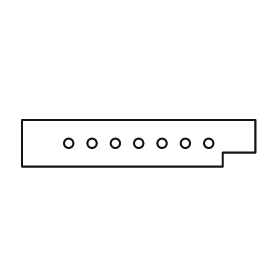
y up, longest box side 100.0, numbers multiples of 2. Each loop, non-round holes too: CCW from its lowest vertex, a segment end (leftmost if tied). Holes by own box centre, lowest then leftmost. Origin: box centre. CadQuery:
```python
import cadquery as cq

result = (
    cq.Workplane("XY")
    .moveTo(-50.0, -10.0)
    .lineTo(36.0, -10.0)
    .lineTo(36.0, -4.0)
    .lineTo(50.0, -4.0)
    .lineTo(50.0, 10.0)
    .lineTo(-50.0, 10.0)
    .close()
    .moveTo(-30.0, 0.0)
    .circle(2.0)
    .moveTo(-20.0, 0.0)
    .circle(2.0)
    .moveTo(-10.0, 0.0)
    .circle(2.0)
    .moveTo(0.0, 0.0)
    .circle(2.0)
    .moveTo(10.0, 0.0)
    .circle(2.0)
    .moveTo(20.0, 0.0)
    .circle(2.0)
    .moveTo(30.0, 0.0)
    .circle(2.0)
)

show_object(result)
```